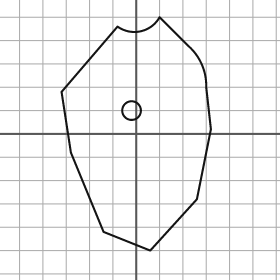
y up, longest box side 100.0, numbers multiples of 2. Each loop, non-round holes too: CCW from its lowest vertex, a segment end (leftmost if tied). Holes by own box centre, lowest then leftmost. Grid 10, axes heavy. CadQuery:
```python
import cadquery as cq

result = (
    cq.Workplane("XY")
    .moveTo(6.0, -50.0)
    .lineTo(26.0, -28.0)
    .lineTo(32.0, 2.0)
    .lineTo(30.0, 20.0)
    .threePointArc((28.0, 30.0), (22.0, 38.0))
    .lineTo(10.0, 50.0)
    .threePointArc((2.0, 44.0), (-8.0, 46.0))
    .lineTo(-32.0, 18.0)
    .lineTo(-28.0, -8.0)
    .lineTo(-14.0, -42.0)
    .close()
    .moveTo(-2.0, 10.0)
    .circle(4.0)
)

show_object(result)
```